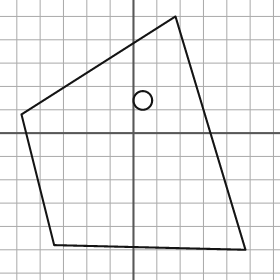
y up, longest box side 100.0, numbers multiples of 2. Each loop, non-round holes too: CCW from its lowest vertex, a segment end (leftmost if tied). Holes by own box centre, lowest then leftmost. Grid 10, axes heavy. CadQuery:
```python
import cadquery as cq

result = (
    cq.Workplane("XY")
    .moveTo(48.0, -50.0)
    .lineTo(18.0, 50.0)
    .lineTo(-48.0, 8.0)
    .lineTo(-34.0, -48.0)
    .close()
    .moveTo(4.0, 14.0)
    .circle(4.0)
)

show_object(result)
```